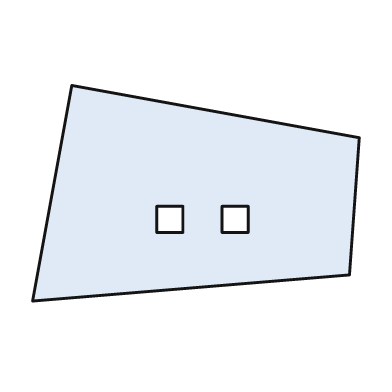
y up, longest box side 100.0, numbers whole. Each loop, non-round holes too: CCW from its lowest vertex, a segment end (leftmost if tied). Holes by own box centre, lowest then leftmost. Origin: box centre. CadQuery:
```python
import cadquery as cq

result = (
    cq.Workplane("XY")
    .moveTo(-50.0, -33.0)
    .lineTo(47.0, -25.0)
    .lineTo(50.0, 17.0)
    .lineTo(-38.0, 33.0)
    .close()
    .moveTo(-12.0, -12.0)
    .lineTo(-4.0, -12.0)
    .lineTo(-4.0, -4.0)
    .lineTo(-12.0, -4.0)
    .close()
    .moveTo(8.0, -12.0)
    .lineTo(16.0, -12.0)
    .lineTo(16.0, -4.0)
    .lineTo(8.0, -4.0)
    .close()
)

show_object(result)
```